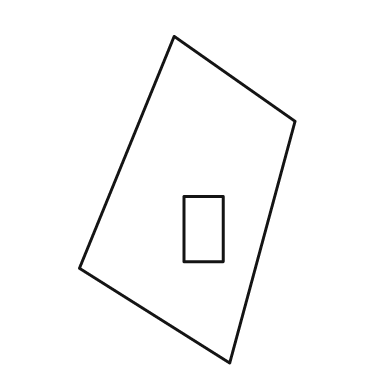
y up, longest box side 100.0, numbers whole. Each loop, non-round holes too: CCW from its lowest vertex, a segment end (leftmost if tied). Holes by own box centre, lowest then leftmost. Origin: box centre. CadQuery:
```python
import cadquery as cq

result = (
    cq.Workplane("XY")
    .moveTo(13.0, -50.0)
    .lineTo(33.0, 24.0)
    .lineTo(-4.0, 50.0)
    .lineTo(-33.0, -21.0)
    .close()
    .moveTo(-1.0, -19.0)
    .lineTo(11.0, -19.0)
    .lineTo(11.0, 1.0)
    .lineTo(-1.0, 1.0)
    .close()
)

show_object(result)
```